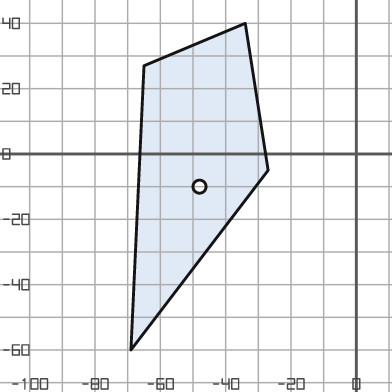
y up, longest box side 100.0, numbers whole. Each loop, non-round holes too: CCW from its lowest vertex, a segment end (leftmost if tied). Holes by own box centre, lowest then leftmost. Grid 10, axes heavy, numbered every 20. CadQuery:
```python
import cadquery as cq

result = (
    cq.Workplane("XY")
    .moveTo(-69.0, -60.0)
    .lineTo(-27.0, -5.0)
    .lineTo(-34.0, 40.0)
    .lineTo(-65.0, 27.0)
    .close()
    .moveTo(-48.0, -10.0)
    .circle(2.0)
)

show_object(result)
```